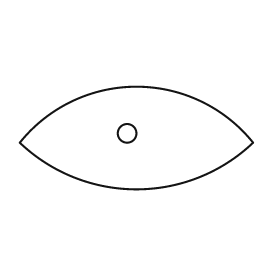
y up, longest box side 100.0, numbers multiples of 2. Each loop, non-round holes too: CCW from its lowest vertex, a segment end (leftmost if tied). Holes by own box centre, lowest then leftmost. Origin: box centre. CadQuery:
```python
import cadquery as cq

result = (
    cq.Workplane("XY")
    .moveTo(-50.0, -2.0)
    .threePointArc((0.0, -22.0), (50.0, -2.0))
    .threePointArc((0.0, 22.0), (-50.0, -2.0))
    .close()
    .moveTo(-4.0, 2.0)
    .circle(4.0)
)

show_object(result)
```